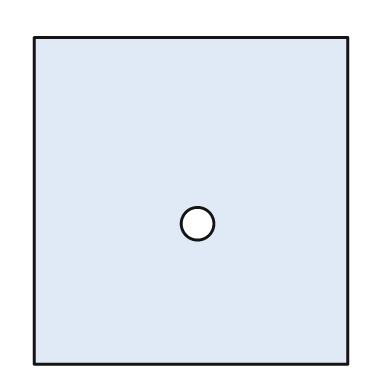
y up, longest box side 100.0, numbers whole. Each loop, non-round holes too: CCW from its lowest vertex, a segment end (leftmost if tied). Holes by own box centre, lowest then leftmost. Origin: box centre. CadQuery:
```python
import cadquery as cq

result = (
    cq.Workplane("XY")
    .moveTo(-48.0, -50.0)
    .lineTo(48.0, -50.0)
    .lineTo(48.0, 50.0)
    .lineTo(-48.0, 50.0)
    .close()
    .moveTo(2.0, -7.0)
    .circle(5.0)
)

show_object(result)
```